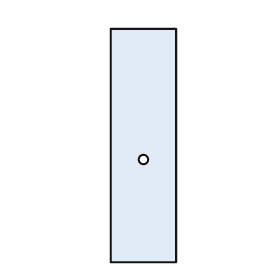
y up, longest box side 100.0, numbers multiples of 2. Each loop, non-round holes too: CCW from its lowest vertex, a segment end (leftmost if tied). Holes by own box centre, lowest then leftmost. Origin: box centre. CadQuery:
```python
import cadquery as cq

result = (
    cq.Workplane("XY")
    .moveTo(-14.0, -50.0)
    .lineTo(14.0, -50.0)
    .lineTo(14.0, 50.0)
    .lineTo(-14.0, 50.0)
    .close()
    .moveTo(0.0, -6.0)
    .circle(2.0)
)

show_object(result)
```